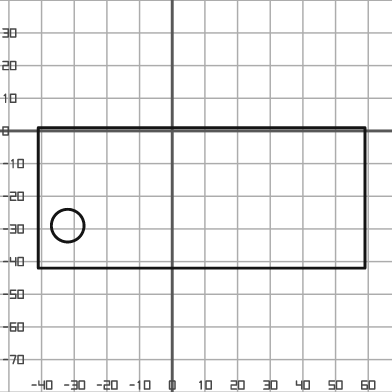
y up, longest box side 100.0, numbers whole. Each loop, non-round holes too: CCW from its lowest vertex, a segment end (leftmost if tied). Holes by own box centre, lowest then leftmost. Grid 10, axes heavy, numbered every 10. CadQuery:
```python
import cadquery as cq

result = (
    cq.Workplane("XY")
    .moveTo(-41.0, -42.0)
    .lineTo(59.0, -42.0)
    .lineTo(59.0, 1.0)
    .lineTo(-41.0, 1.0)
    .close()
    .moveTo(-32.0, -29.0)
    .circle(5.0)
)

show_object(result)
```